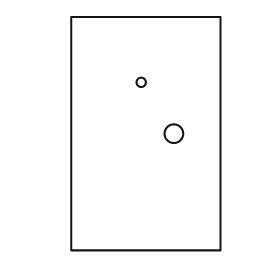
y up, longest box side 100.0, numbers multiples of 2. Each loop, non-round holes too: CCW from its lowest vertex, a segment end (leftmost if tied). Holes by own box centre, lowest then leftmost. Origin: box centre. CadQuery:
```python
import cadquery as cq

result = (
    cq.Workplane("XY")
    .moveTo(-32.0, -50.0)
    .lineTo(32.0, -50.0)
    .lineTo(32.0, 50.0)
    .lineTo(-32.0, 50.0)
    .close()
    .moveTo(12.0, 0.0)
    .circle(4.0)
    .moveTo(-2.0, 22.0)
    .circle(2.0)
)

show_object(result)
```